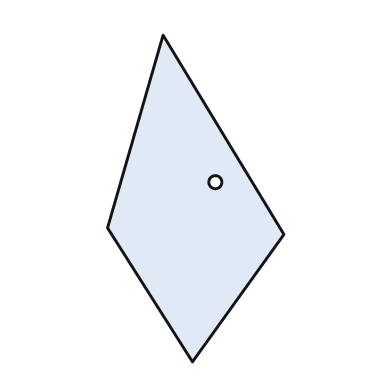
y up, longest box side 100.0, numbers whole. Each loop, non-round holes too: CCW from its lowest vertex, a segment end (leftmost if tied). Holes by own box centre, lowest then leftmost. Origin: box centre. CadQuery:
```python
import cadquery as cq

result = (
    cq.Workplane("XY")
    .moveTo(-1.0, -50.0)
    .lineTo(27.0, -11.0)
    .lineTo(-10.0, 50.0)
    .lineTo(-27.0, -9.0)
    .close()
    .moveTo(6.0, 5.0)
    .circle(2.0)
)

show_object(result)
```